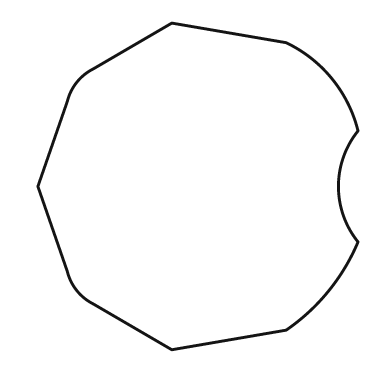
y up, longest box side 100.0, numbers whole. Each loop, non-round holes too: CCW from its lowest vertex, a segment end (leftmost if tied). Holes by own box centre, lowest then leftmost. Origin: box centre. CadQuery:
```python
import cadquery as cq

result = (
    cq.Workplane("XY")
    .moveTo(-8.0, -50.0)
    .lineTo(27.0, -44.0)
    .threePointArc((40.0, -32.0), (49.0, -17.0))
    .threePointArc((43.0, 0.0), (49.0, 17.0))
    .threePointArc((41.0, 33.0), (27.0, 44.0))
    .lineTo(-8.0, 50.0)
    .lineTo(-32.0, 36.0)
    .threePointArc((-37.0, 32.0), (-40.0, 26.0))
    .lineTo(-49.0, 0.0)
    .lineTo(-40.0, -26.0)
    .threePointArc((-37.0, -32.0), (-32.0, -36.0))
    .close()
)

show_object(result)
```